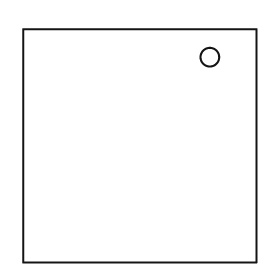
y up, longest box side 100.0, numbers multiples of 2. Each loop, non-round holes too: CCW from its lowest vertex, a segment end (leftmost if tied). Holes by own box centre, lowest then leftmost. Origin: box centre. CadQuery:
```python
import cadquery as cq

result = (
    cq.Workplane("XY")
    .moveTo(-50.0, -50.0)
    .lineTo(50.0, -50.0)
    .lineTo(50.0, 50.0)
    .lineTo(-50.0, 50.0)
    .close()
    .moveTo(30.0, 38.0)
    .circle(4.0)
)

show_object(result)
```